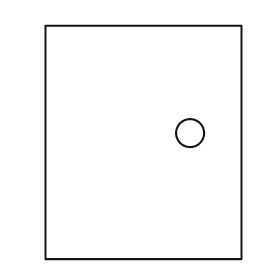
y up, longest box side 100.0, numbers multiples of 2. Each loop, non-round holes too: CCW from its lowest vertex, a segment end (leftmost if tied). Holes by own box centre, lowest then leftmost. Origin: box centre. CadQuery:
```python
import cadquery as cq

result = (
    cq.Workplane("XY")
    .moveTo(-42.0, -50.0)
    .lineTo(42.0, -50.0)
    .lineTo(42.0, 50.0)
    .lineTo(-42.0, 50.0)
    .close()
    .moveTo(20.0, 4.0)
    .circle(6.0)
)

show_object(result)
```